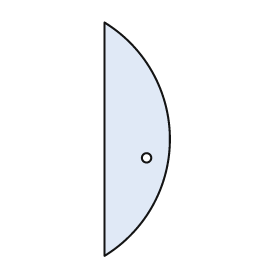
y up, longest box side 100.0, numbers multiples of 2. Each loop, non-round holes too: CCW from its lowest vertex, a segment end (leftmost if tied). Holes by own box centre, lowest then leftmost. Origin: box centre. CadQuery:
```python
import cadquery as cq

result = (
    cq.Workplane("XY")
    .moveTo(-14.0, -50.0)
    .threePointArc((14.0, 0.0), (-14.0, 50.0))
    .close()
    .moveTo(4.0, -8.0)
    .circle(2.0)
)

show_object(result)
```